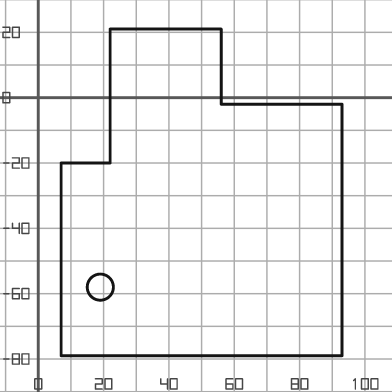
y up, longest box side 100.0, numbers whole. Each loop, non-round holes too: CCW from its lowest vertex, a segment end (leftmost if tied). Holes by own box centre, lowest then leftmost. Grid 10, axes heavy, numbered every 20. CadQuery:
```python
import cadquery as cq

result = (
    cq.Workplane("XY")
    .moveTo(7.0, -79.0)
    .lineTo(93.0, -79.0)
    .lineTo(93.0, -2.0)
    .lineTo(56.0, -2.0)
    .lineTo(56.0, 21.0)
    .lineTo(22.0, 21.0)
    .lineTo(22.0, -20.0)
    .lineTo(7.0, -20.0)
    .close()
    .moveTo(19.0, -58.0)
    .circle(4.0)
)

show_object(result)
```